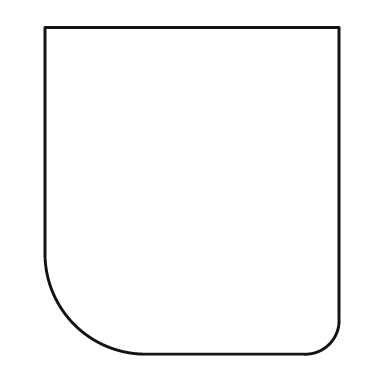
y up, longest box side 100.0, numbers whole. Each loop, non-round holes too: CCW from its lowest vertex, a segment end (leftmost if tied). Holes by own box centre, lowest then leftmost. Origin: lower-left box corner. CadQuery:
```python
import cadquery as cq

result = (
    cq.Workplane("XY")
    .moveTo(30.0, 0.0)
    .lineTo(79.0, 0.0)
    .threePointArc((87.0, 3.0), (90.0, 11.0))
    .lineTo(90.0, 100.0)
    .lineTo(0.0, 100.0)
    .lineTo(0.0, 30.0)
    .threePointArc((9.0, 9.0), (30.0, 0.0))
    .close()
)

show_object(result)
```